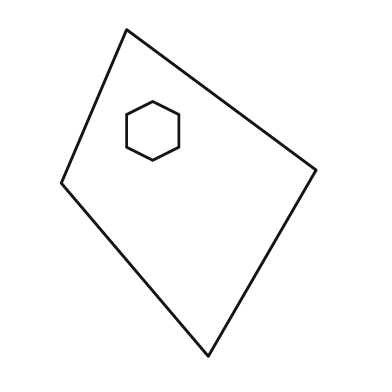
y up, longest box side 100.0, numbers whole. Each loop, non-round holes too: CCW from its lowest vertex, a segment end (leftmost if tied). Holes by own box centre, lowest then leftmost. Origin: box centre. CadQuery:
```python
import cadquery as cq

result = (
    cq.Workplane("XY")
    .moveTo(6.0, -50.0)
    .lineTo(39.0, 7.0)
    .lineTo(-19.0, 50.0)
    .lineTo(-39.0, 3.0)
    .close()
    .moveTo(-11.0, 10.0)
    .lineTo(-3.0, 14.0)
    .lineTo(-3.0, 24.0)
    .lineTo(-11.0, 28.0)
    .lineTo(-19.0, 24.0)
    .lineTo(-19.0, 14.0)
    .close()
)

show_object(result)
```